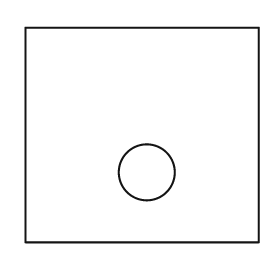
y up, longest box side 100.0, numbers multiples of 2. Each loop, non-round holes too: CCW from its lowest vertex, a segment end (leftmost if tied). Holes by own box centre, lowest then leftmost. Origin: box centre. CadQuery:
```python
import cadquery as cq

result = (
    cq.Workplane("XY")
    .moveTo(-50.0, -46.0)
    .lineTo(50.0, -46.0)
    .lineTo(50.0, 46.0)
    .lineTo(-50.0, 46.0)
    .close()
    .moveTo(2.0, -16.0)
    .circle(12.0)
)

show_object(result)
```